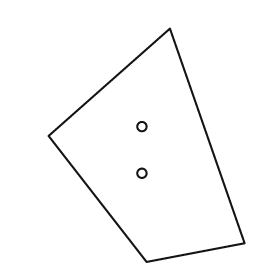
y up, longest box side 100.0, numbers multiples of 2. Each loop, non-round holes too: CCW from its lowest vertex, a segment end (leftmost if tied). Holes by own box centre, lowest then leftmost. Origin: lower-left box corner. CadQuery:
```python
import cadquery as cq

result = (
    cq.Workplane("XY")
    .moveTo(42.0, 0.0)
    .lineTo(84.0, 8.0)
    .lineTo(52.0, 100.0)
    .lineTo(0.0, 54.0)
    .close()
    .moveTo(40.0, 38.0)
    .circle(2.0)
    .moveTo(40.0, 58.0)
    .circle(2.0)
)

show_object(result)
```